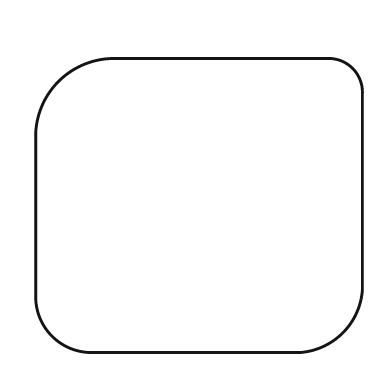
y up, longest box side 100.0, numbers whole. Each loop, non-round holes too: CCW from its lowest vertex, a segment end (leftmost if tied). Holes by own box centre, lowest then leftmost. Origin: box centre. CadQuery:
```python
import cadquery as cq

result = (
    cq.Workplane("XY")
    .moveTo(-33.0, -45.0)
    .lineTo(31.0, -45.0)
    .threePointArc((44.0, -39.0), (50.0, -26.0))
    .lineTo(50.0, 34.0)
    .threePointArc((47.0, 42.0), (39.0, 45.0))
    .lineTo(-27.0, 45.0)
    .threePointArc((-43.0, 38.0), (-50.0, 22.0))
    .lineTo(-50.0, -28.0)
    .threePointArc((-45.0, -40.0), (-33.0, -45.0))
    .close()
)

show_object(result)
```